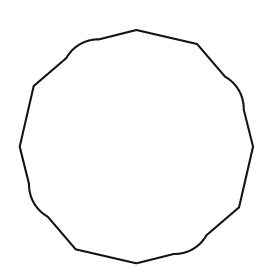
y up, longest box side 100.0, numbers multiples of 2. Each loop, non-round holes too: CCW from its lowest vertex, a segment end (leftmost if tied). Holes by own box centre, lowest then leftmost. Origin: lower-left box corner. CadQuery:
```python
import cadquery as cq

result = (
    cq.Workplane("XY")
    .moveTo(50.0, 0.0)
    .lineTo(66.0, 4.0)
    .threePointArc((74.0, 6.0), (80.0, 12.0))
    .lineTo(94.0, 24.0)
    .lineTo(100.0, 50.0)
    .lineTo(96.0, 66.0)
    .threePointArc((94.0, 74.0), (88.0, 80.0))
    .lineTo(76.0, 94.0)
    .lineTo(50.0, 100.0)
    .lineTo(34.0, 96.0)
    .threePointArc((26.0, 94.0), (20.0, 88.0))
    .lineTo(6.0, 76.0)
    .lineTo(0.0, 50.0)
    .lineTo(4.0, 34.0)
    .threePointArc((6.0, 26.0), (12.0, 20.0))
    .lineTo(24.0, 6.0)
    .close()
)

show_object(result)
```